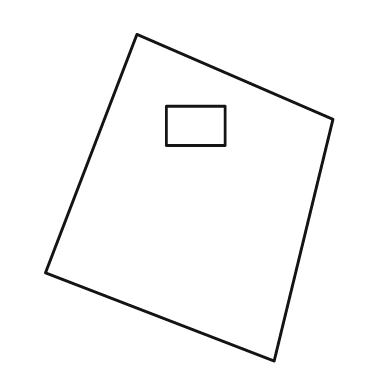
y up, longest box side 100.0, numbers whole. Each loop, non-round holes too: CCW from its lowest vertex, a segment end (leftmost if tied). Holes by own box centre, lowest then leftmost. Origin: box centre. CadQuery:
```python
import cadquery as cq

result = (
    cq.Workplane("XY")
    .moveTo(26.0, -50.0)
    .lineTo(44.0, 24.0)
    .lineTo(-16.0, 50.0)
    .lineTo(-44.0, -23.0)
    .close()
    .moveTo(-7.0, 16.0)
    .lineTo(11.0, 16.0)
    .lineTo(11.0, 28.0)
    .lineTo(-7.0, 28.0)
    .close()
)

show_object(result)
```